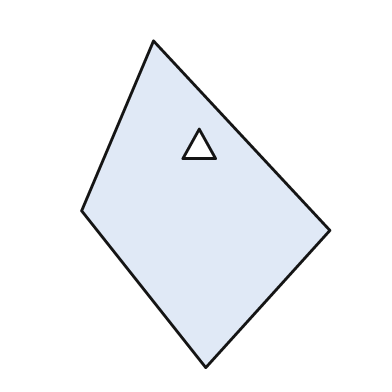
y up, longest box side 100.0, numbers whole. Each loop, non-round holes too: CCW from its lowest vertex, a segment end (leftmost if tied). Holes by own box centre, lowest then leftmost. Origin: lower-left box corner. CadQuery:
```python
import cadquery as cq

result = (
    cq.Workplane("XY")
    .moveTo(38.0, 0.0)
    .lineTo(76.0, 42.0)
    .lineTo(22.0, 100.0)
    .lineTo(0.0, 48.0)
    .close()
    .moveTo(31.0, 64.0)
    .lineTo(41.0, 64.0)
    .lineTo(36.0, 73.0)
    .close()
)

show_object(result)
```